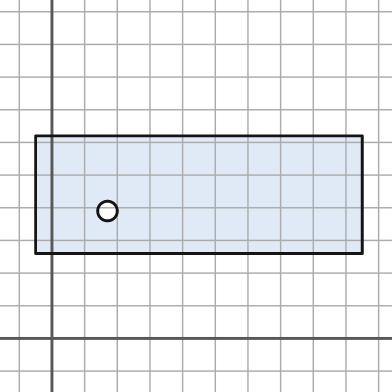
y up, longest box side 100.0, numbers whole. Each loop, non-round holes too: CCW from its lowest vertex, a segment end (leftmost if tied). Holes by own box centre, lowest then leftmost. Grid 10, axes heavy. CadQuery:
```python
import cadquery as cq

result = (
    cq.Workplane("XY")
    .moveTo(-5.0, 26.0)
    .lineTo(95.0, 26.0)
    .lineTo(95.0, 62.0)
    .lineTo(-5.0, 62.0)
    .close()
    .moveTo(17.0, 39.0)
    .circle(3.0)
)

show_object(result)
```